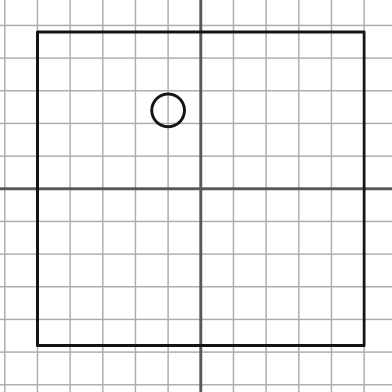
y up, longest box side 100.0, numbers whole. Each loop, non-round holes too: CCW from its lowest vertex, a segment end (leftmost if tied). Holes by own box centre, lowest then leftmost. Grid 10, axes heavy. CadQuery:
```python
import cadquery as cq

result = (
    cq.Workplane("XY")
    .moveTo(-50.0, -48.0)
    .lineTo(50.0, -48.0)
    .lineTo(50.0, 48.0)
    .lineTo(-50.0, 48.0)
    .close()
    .moveTo(-10.0, 24.0)
    .circle(5.0)
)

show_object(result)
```